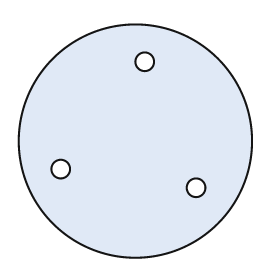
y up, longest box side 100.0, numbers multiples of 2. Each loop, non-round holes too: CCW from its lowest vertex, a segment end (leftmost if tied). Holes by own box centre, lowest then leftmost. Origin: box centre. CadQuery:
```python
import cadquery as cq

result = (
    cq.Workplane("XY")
    .moveTo(0.0, 0.0)
    .circle(50.0)
    .moveTo(26.0, -20.0)
    .circle(4.0)
    .moveTo(-32.0, -12.0)
    .circle(4.0)
    .moveTo(4.0, 34.0)
    .circle(4.0)
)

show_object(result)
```